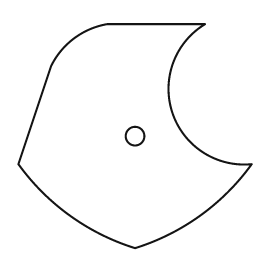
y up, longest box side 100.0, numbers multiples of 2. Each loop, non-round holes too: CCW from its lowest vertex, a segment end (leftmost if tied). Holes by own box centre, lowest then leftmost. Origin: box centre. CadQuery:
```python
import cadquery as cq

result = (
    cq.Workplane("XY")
    .moveTo(0.0, -48.0)
    .threePointArc((28.0, -34.0), (50.0, -12.0))
    .threePointArc((16.0, 10.0), (30.0, 48.0))
    .lineTo(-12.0, 48.0)
    .threePointArc((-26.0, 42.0), (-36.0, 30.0))
    .lineTo(-50.0, -12.0)
    .threePointArc((-28.0, -34.0), (0.0, -48.0))
    .close()
    .moveTo(0.0, 0.0)
    .circle(4.0)
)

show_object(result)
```